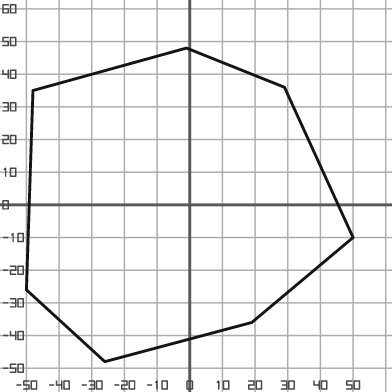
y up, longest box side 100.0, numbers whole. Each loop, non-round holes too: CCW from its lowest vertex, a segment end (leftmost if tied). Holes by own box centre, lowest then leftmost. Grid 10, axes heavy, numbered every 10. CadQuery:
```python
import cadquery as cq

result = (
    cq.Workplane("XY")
    .moveTo(-26.0, -48.0)
    .lineTo(19.0, -36.0)
    .lineTo(50.0, -10.0)
    .lineTo(29.0, 36.0)
    .lineTo(-1.0, 48.0)
    .lineTo(-48.0, 35.0)
    .lineTo(-50.0, -26.0)
    .close()
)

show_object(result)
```